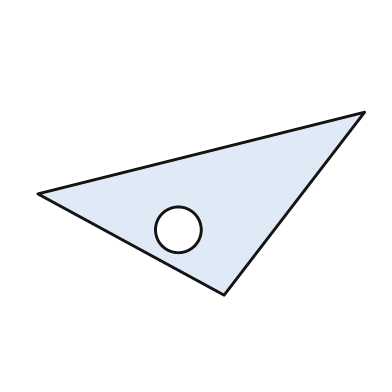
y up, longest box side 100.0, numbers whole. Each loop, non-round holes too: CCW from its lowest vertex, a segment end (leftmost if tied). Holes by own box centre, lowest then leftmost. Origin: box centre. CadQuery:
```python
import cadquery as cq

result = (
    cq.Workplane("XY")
    .moveTo(7.0, -28.0)
    .lineTo(50.0, 28.0)
    .lineTo(-50.0, 3.0)
    .close()
    .moveTo(-7.0, -8.0)
    .circle(7.0)
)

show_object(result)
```